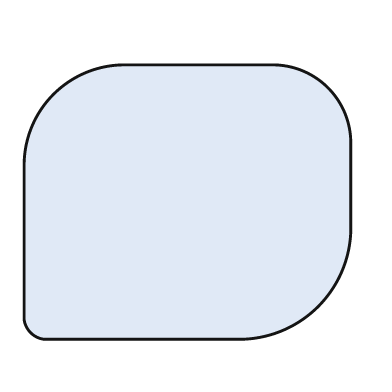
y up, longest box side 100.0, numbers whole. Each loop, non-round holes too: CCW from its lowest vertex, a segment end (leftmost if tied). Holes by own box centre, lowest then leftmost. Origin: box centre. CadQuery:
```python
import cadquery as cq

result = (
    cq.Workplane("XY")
    .moveTo(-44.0, -42.0)
    .lineTo(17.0, -42.0)
    .threePointArc((40.0, -32.0), (50.0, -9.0))
    .lineTo(50.0, 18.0)
    .threePointArc((43.0, 35.0), (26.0, 42.0))
    .lineTo(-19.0, 42.0)
    .threePointArc((-41.0, 33.0), (-50.0, 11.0))
    .lineTo(-50.0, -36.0)
    .threePointArc((-48.0, -40.0), (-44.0, -42.0))
    .close()
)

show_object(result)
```